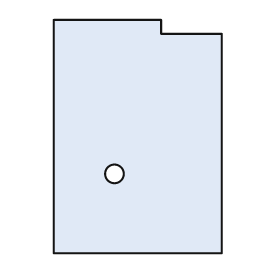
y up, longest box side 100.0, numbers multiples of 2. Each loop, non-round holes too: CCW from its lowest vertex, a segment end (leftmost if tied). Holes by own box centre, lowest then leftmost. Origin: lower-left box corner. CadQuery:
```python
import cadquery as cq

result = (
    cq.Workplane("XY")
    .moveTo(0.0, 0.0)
    .lineTo(72.0, 0.0)
    .lineTo(72.0, 94.0)
    .lineTo(46.0, 94.0)
    .lineTo(46.0, 100.0)
    .lineTo(0.0, 100.0)
    .close()
    .moveTo(26.0, 34.0)
    .circle(4.0)
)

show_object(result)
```